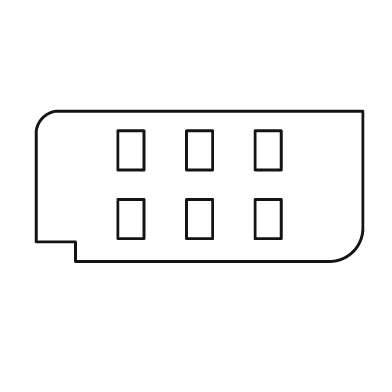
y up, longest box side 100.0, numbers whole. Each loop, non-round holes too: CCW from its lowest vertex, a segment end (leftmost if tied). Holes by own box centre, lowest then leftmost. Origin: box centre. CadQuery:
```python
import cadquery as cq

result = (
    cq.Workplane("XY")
    .moveTo(-38.0, -23.0)
    .lineTo(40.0, -23.0)
    .threePointArc((47.0, -20.0), (50.0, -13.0))
    .lineTo(50.0, 23.0)
    .lineTo(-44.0, 23.0)
    .threePointArc((-48.0, 21.0), (-50.0, 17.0))
    .lineTo(-50.0, -17.0)
    .lineTo(-38.0, -17.0)
    .close()
    .moveTo(-25.0, -16.0)
    .lineTo(-17.0, -16.0)
    .lineTo(-17.0, -4.0)
    .lineTo(-25.0, -4.0)
    .close()
    .moveTo(-4.0, -16.0)
    .lineTo(4.0, -16.0)
    .lineTo(4.0, -4.0)
    .lineTo(-4.0, -4.0)
    .close()
    .moveTo(17.0, -16.0)
    .lineTo(25.0, -16.0)
    .lineTo(25.0, -4.0)
    .lineTo(17.0, -4.0)
    .close()
    .moveTo(-25.0, 5.0)
    .lineTo(-17.0, 5.0)
    .lineTo(-17.0, 17.0)
    .lineTo(-25.0, 17.0)
    .close()
    .moveTo(-4.0, 5.0)
    .lineTo(4.0, 5.0)
    .lineTo(4.0, 17.0)
    .lineTo(-4.0, 17.0)
    .close()
    .moveTo(17.0, 5.0)
    .lineTo(25.0, 5.0)
    .lineTo(25.0, 17.0)
    .lineTo(17.0, 17.0)
    .close()
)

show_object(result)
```